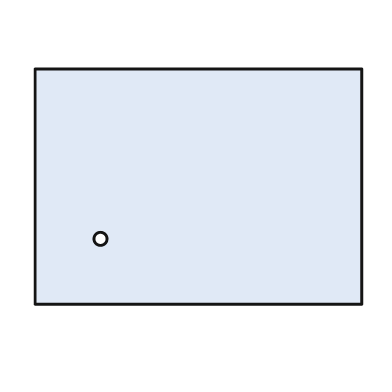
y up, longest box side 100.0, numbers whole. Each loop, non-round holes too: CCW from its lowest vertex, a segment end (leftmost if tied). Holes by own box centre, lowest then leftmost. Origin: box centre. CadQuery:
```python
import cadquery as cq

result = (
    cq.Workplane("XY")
    .moveTo(-50.0, -36.0)
    .lineTo(50.0, -36.0)
    .lineTo(50.0, 36.0)
    .lineTo(-50.0, 36.0)
    .close()
    .moveTo(-30.0, -16.0)
    .circle(2.0)
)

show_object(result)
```